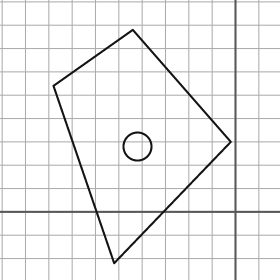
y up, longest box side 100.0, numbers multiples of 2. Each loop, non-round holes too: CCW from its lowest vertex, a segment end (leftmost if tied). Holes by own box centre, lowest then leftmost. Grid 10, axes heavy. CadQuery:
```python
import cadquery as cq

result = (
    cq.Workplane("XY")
    .moveTo(-52.0, -22.0)
    .lineTo(-2.0, 30.0)
    .lineTo(-44.0, 78.0)
    .lineTo(-78.0, 54.0)
    .close()
    .moveTo(-42.0, 28.0)
    .circle(6.0)
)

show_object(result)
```